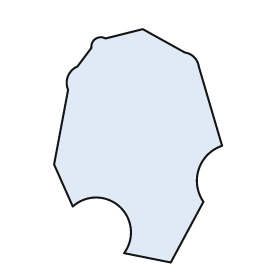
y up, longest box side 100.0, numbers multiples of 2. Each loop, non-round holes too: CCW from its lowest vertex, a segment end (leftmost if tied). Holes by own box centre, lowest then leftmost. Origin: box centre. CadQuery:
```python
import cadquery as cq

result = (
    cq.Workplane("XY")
    .moveTo(14.0, -50.0)
    .lineTo(28.0, -24.0)
    .threePointArc((26.0, -10.0), (36.0, 0.0))
    .lineTo(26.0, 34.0)
    .threePointArc((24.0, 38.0), (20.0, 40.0))
    .lineTo(2.0, 50.0)
    .lineTo(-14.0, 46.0)
    .threePointArc((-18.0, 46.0), (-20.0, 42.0))
    .lineTo(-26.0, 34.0)
    .threePointArc((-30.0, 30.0), (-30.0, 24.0))
    .lineTo(-36.0, -8.0)
    .lineTo(-28.0, -26.0)
    .threePointArc((-8.0, -26.0), (-6.0, -46.0))
    .close()
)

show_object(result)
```